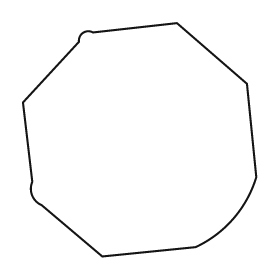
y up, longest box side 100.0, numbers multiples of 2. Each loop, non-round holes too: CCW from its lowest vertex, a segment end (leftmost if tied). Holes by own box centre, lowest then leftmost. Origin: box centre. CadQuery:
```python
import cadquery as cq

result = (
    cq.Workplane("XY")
    .moveTo(-16.0, -50.0)
    .lineTo(24.0, -46.0)
    .threePointArc((40.0, -34.0), (50.0, -16.0))
    .lineTo(46.0, 24.0)
    .lineTo(16.0, 50.0)
    .lineTo(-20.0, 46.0)
    .threePointArc((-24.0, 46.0), (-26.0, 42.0))
    .lineTo(-50.0, 16.0)
    .lineTo(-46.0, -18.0)
    .threePointArc((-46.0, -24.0), (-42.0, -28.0))
    .close()
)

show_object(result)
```